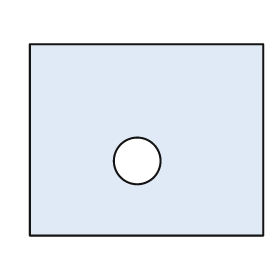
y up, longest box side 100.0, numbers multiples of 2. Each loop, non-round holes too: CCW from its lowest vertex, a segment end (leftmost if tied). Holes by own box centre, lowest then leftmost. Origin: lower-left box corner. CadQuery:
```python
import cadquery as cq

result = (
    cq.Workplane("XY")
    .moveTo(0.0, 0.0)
    .lineTo(100.0, 0.0)
    .lineTo(100.0, 82.0)
    .lineTo(0.0, 82.0)
    .close()
    .moveTo(46.0, 32.0)
    .circle(10.0)
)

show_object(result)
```